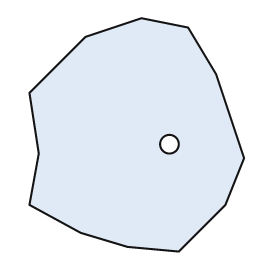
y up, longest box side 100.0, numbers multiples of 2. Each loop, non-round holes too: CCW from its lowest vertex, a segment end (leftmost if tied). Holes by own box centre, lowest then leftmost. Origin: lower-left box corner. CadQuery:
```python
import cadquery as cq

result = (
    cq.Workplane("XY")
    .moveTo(64.0, 0.0)
    .lineTo(84.0, 20.0)
    .lineTo(92.0, 40.0)
    .lineTo(80.0, 76.0)
    .lineTo(68.0, 96.0)
    .lineTo(48.0, 100.0)
    .lineTo(24.0, 92.0)
    .lineTo(0.0, 68.0)
    .lineTo(4.0, 42.0)
    .lineTo(0.0, 20.0)
    .lineTo(22.0, 8.0)
    .lineTo(42.0, 2.0)
    .close()
    .moveTo(60.0, 46.0)
    .circle(4.0)
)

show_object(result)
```